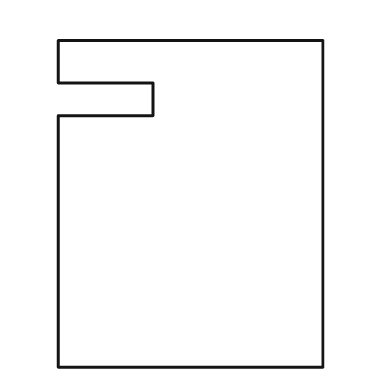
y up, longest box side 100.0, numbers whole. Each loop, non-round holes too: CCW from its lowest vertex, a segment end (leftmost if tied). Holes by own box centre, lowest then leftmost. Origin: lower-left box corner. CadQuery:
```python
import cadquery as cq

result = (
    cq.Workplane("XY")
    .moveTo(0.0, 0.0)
    .lineTo(81.0, 0.0)
    .lineTo(81.0, 100.0)
    .lineTo(0.0, 100.0)
    .lineTo(0.0, 87.0)
    .lineTo(29.0, 87.0)
    .lineTo(29.0, 77.0)
    .lineTo(0.0, 77.0)
    .close()
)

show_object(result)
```